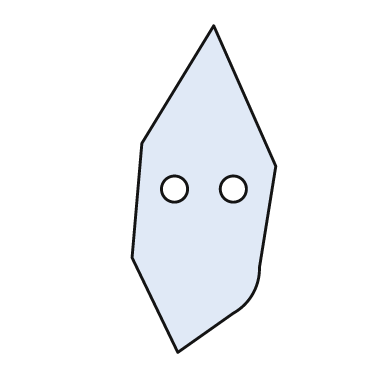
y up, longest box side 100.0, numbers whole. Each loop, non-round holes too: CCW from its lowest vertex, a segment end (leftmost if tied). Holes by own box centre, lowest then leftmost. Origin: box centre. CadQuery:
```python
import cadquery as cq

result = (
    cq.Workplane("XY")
    .moveTo(-8.0, -50.0)
    .lineTo(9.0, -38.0)
    .threePointArc((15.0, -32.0), (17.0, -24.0))
    .lineTo(22.0, 7.0)
    .lineTo(3.0, 50.0)
    .lineTo(-19.0, 14.0)
    .lineTo(-22.0, -21.0)
    .close()
    .moveTo(-9.0, 0.0)
    .circle(4.0)
    .moveTo(9.0, 0.0)
    .circle(4.0)
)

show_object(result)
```